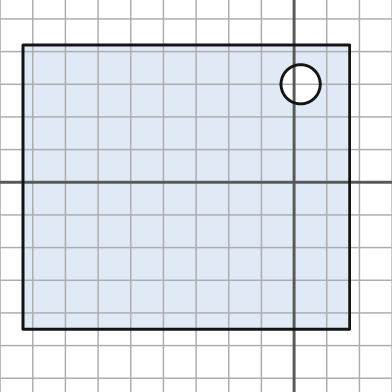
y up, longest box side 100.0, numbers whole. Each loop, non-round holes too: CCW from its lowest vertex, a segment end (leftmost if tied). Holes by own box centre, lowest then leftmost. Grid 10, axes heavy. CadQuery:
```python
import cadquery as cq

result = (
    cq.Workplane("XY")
    .moveTo(-83.0, -45.0)
    .lineTo(17.0, -45.0)
    .lineTo(17.0, 42.0)
    .lineTo(-83.0, 42.0)
    .close()
    .moveTo(2.0, 30.0)
    .circle(6.0)
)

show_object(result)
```